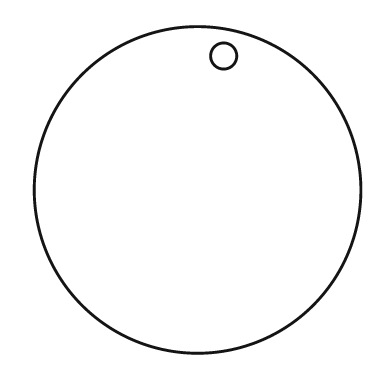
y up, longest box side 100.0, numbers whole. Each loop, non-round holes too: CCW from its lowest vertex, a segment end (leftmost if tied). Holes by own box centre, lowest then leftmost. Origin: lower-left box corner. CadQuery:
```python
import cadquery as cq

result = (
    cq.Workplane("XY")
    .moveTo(50.0, 50.0)
    .circle(50.0)
    .moveTo(58.0, 91.0)
    .circle(4.0)
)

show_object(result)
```